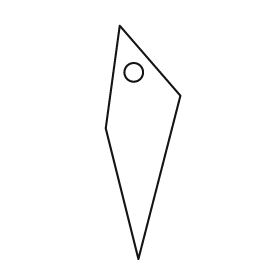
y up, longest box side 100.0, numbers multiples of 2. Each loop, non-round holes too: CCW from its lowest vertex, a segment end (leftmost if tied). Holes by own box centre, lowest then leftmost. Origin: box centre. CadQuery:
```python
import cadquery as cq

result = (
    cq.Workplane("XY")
    .moveTo(-2.0, -50.0)
    .lineTo(16.0, 20.0)
    .lineTo(-10.0, 50.0)
    .lineTo(-16.0, 6.0)
    .close()
    .moveTo(-4.0, 30.0)
    .circle(4.0)
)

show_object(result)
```